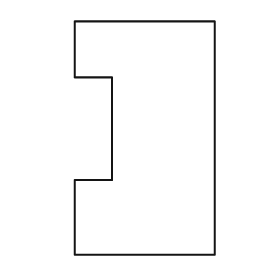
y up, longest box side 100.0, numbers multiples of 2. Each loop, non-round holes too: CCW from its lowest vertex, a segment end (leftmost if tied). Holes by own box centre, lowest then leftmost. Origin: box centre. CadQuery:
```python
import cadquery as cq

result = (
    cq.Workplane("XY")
    .moveTo(-30.0, -50.0)
    .lineTo(30.0, -50.0)
    .lineTo(30.0, 50.0)
    .lineTo(-30.0, 50.0)
    .lineTo(-30.0, 26.0)
    .lineTo(-14.0, 26.0)
    .lineTo(-14.0, -18.0)
    .lineTo(-30.0, -18.0)
    .close()
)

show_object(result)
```